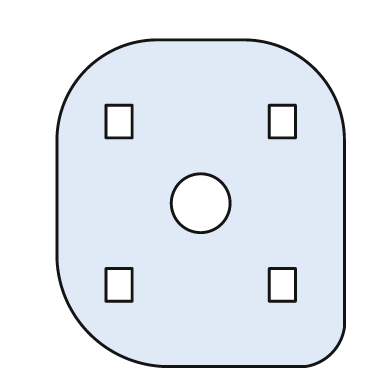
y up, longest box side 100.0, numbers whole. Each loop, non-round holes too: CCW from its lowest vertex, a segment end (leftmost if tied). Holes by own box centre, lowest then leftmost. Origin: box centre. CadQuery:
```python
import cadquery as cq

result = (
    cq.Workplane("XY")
    .moveTo(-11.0, -50.0)
    .lineTo(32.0, -50.0)
    .threePointArc((40.0, -46.0), (44.0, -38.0))
    .lineTo(44.0, 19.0)
    .threePointArc((35.0, 41.0), (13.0, 50.0))
    .lineTo(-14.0, 50.0)
    .threePointArc((-35.0, 41.0), (-44.0, 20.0))
    .lineTo(-44.0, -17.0)
    .threePointArc((-34.0, -40.0), (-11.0, -50.0))
    .close()
    .moveTo(-29.0, -30.0)
    .lineTo(-21.0, -30.0)
    .lineTo(-21.0, -20.0)
    .lineTo(-29.0, -20.0)
    .close()
    .moveTo(21.0, -30.0)
    .lineTo(29.0, -30.0)
    .lineTo(29.0, -20.0)
    .lineTo(21.0, -20.0)
    .close()
    .moveTo(0.0, 0.0)
    .circle(9.0)
    .moveTo(-29.0, 20.0)
    .lineTo(-21.0, 20.0)
    .lineTo(-21.0, 30.0)
    .lineTo(-29.0, 30.0)
    .close()
    .moveTo(21.0, 20.0)
    .lineTo(29.0, 20.0)
    .lineTo(29.0, 30.0)
    .lineTo(21.0, 30.0)
    .close()
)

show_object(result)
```